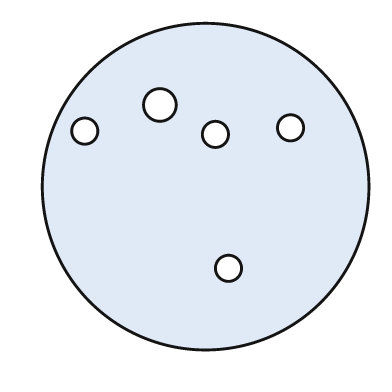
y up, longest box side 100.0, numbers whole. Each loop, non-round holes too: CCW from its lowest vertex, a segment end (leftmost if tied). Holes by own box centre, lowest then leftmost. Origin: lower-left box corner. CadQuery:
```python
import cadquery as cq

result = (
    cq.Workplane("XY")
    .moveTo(50.0, 50.0)
    .circle(50.0)
    .moveTo(57.0, 25.0)
    .circle(4.0)
    .moveTo(53.0, 66.0)
    .circle(4.0)
    .moveTo(13.0, 67.0)
    .circle(4.0)
    .moveTo(76.0, 68.0)
    .circle(4.0)
    .moveTo(36.0, 75.0)
    .circle(5.0)
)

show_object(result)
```